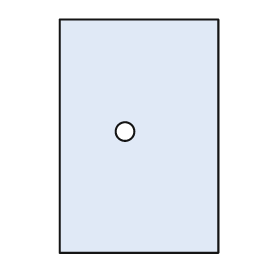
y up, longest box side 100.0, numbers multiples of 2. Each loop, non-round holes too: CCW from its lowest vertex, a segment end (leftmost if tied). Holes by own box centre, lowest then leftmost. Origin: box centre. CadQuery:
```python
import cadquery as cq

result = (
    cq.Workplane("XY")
    .moveTo(-34.0, -50.0)
    .lineTo(34.0, -50.0)
    .lineTo(34.0, 50.0)
    .lineTo(-34.0, 50.0)
    .close()
    .moveTo(-6.0, 2.0)
    .circle(4.0)
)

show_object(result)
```